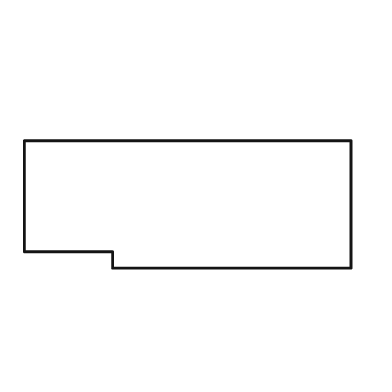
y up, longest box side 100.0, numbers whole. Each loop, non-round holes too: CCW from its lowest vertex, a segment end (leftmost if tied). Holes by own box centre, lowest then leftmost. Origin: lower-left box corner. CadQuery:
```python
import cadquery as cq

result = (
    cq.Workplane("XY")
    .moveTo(27.0, 0.0)
    .lineTo(100.0, 0.0)
    .lineTo(100.0, 39.0)
    .lineTo(0.0, 39.0)
    .lineTo(0.0, 5.0)
    .lineTo(27.0, 5.0)
    .close()
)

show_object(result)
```